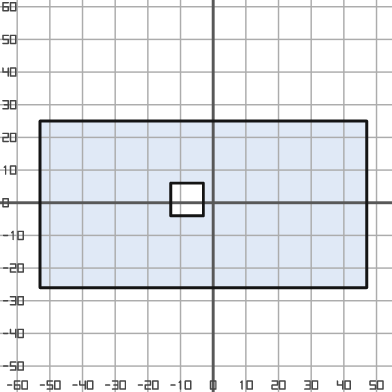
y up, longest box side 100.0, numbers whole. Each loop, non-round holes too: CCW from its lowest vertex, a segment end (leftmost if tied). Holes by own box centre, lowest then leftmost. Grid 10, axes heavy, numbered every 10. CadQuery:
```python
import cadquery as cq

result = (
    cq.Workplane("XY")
    .moveTo(-53.0, -26.0)
    .lineTo(47.0, -26.0)
    .lineTo(47.0, 25.0)
    .lineTo(-53.0, 25.0)
    .close()
    .moveTo(-13.0, -4.0)
    .lineTo(-3.0, -4.0)
    .lineTo(-3.0, 6.0)
    .lineTo(-13.0, 6.0)
    .close()
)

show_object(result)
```